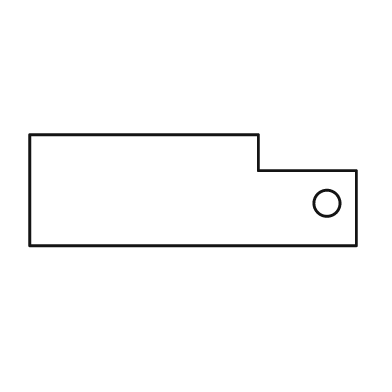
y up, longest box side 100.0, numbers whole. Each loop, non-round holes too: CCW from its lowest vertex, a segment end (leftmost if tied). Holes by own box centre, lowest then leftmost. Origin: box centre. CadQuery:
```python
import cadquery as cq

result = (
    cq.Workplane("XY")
    .moveTo(-50.0, -17.0)
    .lineTo(50.0, -17.0)
    .lineTo(50.0, 6.0)
    .lineTo(20.0, 6.0)
    .lineTo(20.0, 17.0)
    .lineTo(-50.0, 17.0)
    .close()
    .moveTo(41.0, -4.0)
    .circle(4.0)
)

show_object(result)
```